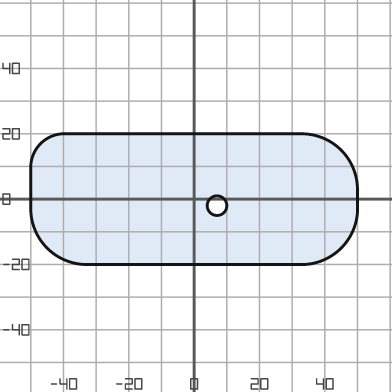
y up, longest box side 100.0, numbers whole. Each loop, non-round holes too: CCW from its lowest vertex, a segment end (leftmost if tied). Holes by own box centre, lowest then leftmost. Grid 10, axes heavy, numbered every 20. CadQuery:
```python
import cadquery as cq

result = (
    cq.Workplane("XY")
    .moveTo(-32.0, -20.0)
    .lineTo(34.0, -20.0)
    .threePointArc((45.0, -15.0), (50.0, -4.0))
    .lineTo(50.0, 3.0)
    .threePointArc((45.0, 15.0), (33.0, 20.0))
    .lineTo(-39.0, 20.0)
    .threePointArc((-47.0, 17.0), (-50.0, 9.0))
    .lineTo(-50.0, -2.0)
    .threePointArc((-45.0, -15.0), (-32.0, -20.0))
    .close()
    .moveTo(7.0, -2.0)
    .circle(3.0)
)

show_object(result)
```